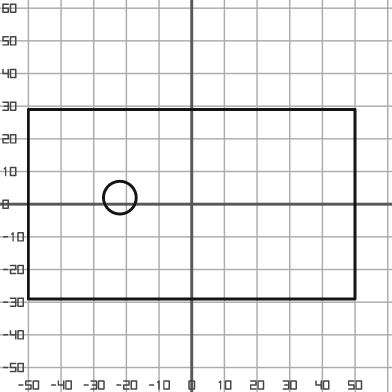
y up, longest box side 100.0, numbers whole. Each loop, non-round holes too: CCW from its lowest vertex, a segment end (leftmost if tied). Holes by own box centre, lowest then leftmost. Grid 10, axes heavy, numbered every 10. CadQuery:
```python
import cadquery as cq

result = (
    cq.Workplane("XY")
    .moveTo(-50.0, -29.0)
    .lineTo(50.0, -29.0)
    .lineTo(50.0, 29.0)
    .lineTo(-50.0, 29.0)
    .close()
    .moveTo(-22.0, 2.0)
    .circle(5.0)
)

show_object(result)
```